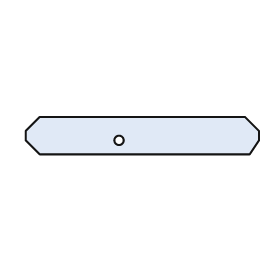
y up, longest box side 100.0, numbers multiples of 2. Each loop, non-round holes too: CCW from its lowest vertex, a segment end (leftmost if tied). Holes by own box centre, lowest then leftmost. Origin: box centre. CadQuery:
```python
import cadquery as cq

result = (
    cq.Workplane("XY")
    .moveTo(-44.0, -8.0)
    .lineTo(46.0, -8.0)
    .lineTo(50.0, -2.0)
    .lineTo(50.0, 2.0)
    .lineTo(44.0, 8.0)
    .lineTo(-44.0, 8.0)
    .lineTo(-50.0, 2.0)
    .lineTo(-50.0, -2.0)
    .close()
    .moveTo(-10.0, -2.0)
    .circle(2.0)
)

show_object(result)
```